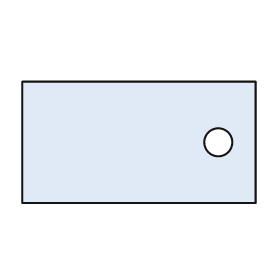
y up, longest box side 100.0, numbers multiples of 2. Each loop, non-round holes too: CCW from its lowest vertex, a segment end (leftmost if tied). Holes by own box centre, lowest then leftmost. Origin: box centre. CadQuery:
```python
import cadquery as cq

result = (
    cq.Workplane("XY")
    .moveTo(-50.0, -26.0)
    .lineTo(50.0, -26.0)
    .lineTo(50.0, 26.0)
    .lineTo(-50.0, 26.0)
    .close()
    .moveTo(34.0, 0.0)
    .circle(6.0)
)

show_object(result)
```